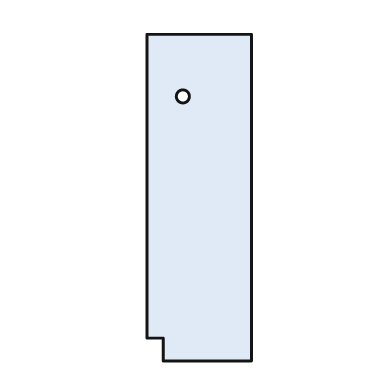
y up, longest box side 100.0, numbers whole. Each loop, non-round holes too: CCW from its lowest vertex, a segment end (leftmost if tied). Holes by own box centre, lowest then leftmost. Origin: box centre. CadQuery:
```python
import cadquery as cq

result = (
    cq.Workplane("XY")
    .moveTo(-11.0, -50.0)
    .lineTo(16.0, -50.0)
    .lineTo(16.0, 50.0)
    .lineTo(-16.0, 50.0)
    .lineTo(-16.0, -43.0)
    .lineTo(-11.0, -43.0)
    .close()
    .moveTo(-5.0, 31.0)
    .circle(2.0)
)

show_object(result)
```